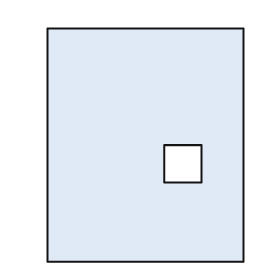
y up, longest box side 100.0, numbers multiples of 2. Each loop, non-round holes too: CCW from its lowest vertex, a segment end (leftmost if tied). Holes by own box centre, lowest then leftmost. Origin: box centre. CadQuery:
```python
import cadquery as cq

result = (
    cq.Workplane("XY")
    .moveTo(-42.0, -50.0)
    .lineTo(42.0, -50.0)
    .lineTo(42.0, 50.0)
    .lineTo(-42.0, 50.0)
    .close()
    .moveTo(8.0, -16.0)
    .lineTo(24.0, -16.0)
    .lineTo(24.0, 0.0)
    .lineTo(8.0, 0.0)
    .close()
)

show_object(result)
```